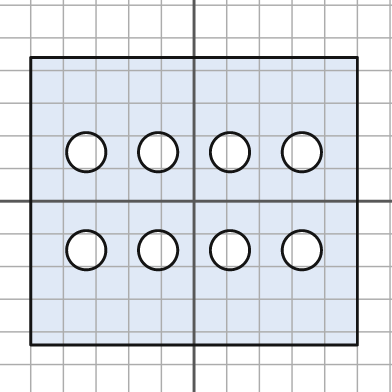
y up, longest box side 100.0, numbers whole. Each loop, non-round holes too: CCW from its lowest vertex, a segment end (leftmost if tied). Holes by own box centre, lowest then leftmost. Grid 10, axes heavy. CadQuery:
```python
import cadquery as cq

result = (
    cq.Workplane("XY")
    .moveTo(-50.0, -44.0)
    .lineTo(50.0, -44.0)
    .lineTo(50.0, 44.0)
    .lineTo(-50.0, 44.0)
    .close()
    .moveTo(-33.0, -15.0)
    .circle(6.0)
    .moveTo(-11.0, -15.0)
    .circle(6.0)
    .moveTo(11.0, -15.0)
    .circle(6.0)
    .moveTo(33.0, -15.0)
    .circle(6.0)
    .moveTo(-33.0, 15.0)
    .circle(6.0)
    .moveTo(-11.0, 15.0)
    .circle(6.0)
    .moveTo(11.0, 15.0)
    .circle(6.0)
    .moveTo(33.0, 15.0)
    .circle(6.0)
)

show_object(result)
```